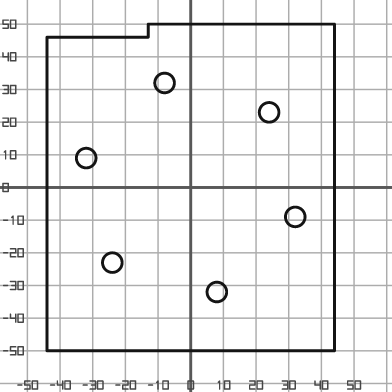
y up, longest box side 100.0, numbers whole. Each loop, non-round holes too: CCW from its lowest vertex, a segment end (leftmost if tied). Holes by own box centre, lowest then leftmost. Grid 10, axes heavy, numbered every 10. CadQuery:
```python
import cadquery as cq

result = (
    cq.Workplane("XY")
    .moveTo(-44.0, -50.0)
    .lineTo(44.0, -50.0)
    .lineTo(44.0, 50.0)
    .lineTo(-13.0, 50.0)
    .lineTo(-13.0, 46.0)
    .lineTo(-44.0, 46.0)
    .close()
    .moveTo(8.0, -32.0)
    .circle(3.0)
    .moveTo(-24.0, -23.0)
    .circle(3.0)
    .moveTo(32.0, -9.0)
    .circle(3.0)
    .moveTo(-32.0, 9.0)
    .circle(3.0)
    .moveTo(24.0, 23.0)
    .circle(3.0)
    .moveTo(-8.0, 32.0)
    .circle(3.0)
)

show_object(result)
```